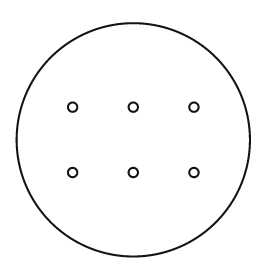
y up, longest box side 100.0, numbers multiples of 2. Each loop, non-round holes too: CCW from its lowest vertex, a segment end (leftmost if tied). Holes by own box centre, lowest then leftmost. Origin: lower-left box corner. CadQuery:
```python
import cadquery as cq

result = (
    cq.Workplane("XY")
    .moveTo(50.0, 50.0)
    .circle(50.0)
    .moveTo(24.0, 36.0)
    .circle(2.0)
    .moveTo(50.0, 36.0)
    .circle(2.0)
    .moveTo(76.0, 36.0)
    .circle(2.0)
    .moveTo(24.0, 64.0)
    .circle(2.0)
    .moveTo(50.0, 64.0)
    .circle(2.0)
    .moveTo(76.0, 64.0)
    .circle(2.0)
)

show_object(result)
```